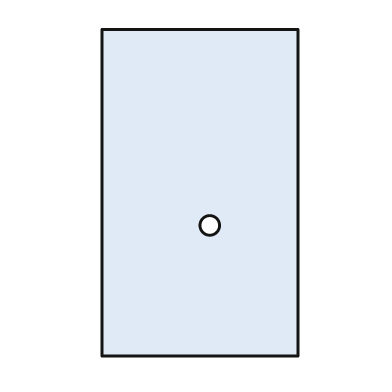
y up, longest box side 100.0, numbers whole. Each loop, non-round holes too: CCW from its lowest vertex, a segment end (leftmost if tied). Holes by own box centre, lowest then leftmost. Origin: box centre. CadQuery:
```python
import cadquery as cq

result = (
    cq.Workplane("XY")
    .moveTo(-30.0, -50.0)
    .lineTo(30.0, -50.0)
    .lineTo(30.0, 50.0)
    .lineTo(-30.0, 50.0)
    .close()
    .moveTo(3.0, -10.0)
    .circle(3.0)
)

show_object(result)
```